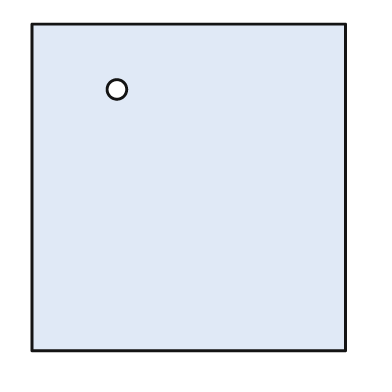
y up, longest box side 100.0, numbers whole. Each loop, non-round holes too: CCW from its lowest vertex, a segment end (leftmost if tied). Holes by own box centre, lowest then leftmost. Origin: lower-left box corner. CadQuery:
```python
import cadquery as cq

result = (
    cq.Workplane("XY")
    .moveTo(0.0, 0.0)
    .lineTo(96.0, 0.0)
    .lineTo(96.0, 100.0)
    .lineTo(0.0, 100.0)
    .close()
    .moveTo(26.0, 80.0)
    .circle(3.0)
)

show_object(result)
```